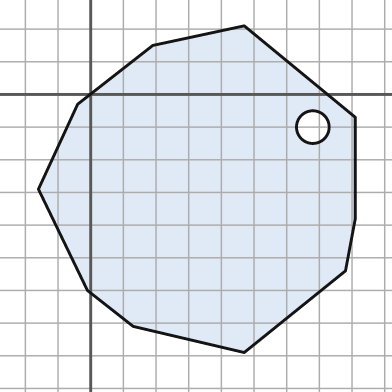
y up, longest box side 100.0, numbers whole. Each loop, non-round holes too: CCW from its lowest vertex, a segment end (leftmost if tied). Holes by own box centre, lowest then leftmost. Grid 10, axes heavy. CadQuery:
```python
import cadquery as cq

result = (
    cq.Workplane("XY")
    .moveTo(47.0, -79.0)
    .lineTo(78.0, -54.0)
    .lineTo(81.0, -38.0)
    .lineTo(81.0, -7.0)
    .lineTo(47.0, 21.0)
    .lineTo(19.0, 15.0)
    .lineTo(-4.0, -3.0)
    .lineTo(-16.0, -29.0)
    .lineTo(-1.0, -60.0)
    .lineTo(13.0, -71.0)
    .close()
    .moveTo(68.0, -10.0)
    .circle(5.0)
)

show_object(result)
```